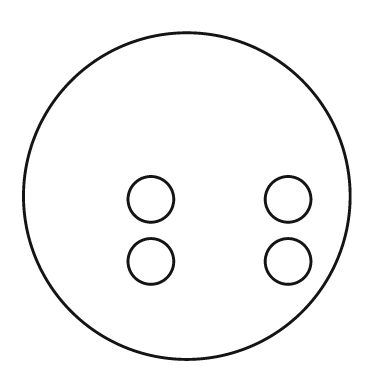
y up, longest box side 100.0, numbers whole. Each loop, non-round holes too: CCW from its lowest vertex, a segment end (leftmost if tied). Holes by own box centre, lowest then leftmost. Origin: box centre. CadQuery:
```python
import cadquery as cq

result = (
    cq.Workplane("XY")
    .moveTo(0.0, 0.0)
    .circle(50.0)
    .moveTo(-11.0, -20.0)
    .circle(7.0)
    .moveTo(31.0, -20.0)
    .circle(7.0)
    .moveTo(-11.0, -1.0)
    .circle(7.0)
    .moveTo(31.0, -1.0)
    .circle(7.0)
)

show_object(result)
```